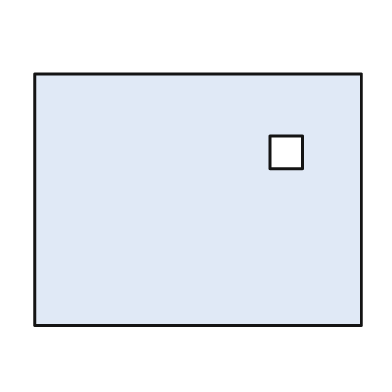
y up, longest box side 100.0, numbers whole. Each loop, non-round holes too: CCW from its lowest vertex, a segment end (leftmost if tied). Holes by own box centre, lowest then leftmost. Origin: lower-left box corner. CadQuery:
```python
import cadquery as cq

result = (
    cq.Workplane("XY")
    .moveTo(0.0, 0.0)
    .lineTo(100.0, 0.0)
    .lineTo(100.0, 77.0)
    .lineTo(0.0, 77.0)
    .close()
    .moveTo(72.0, 48.0)
    .lineTo(82.0, 48.0)
    .lineTo(82.0, 58.0)
    .lineTo(72.0, 58.0)
    .close()
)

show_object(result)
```